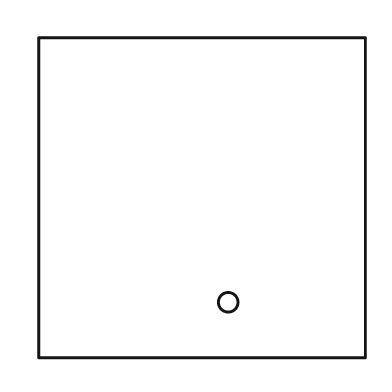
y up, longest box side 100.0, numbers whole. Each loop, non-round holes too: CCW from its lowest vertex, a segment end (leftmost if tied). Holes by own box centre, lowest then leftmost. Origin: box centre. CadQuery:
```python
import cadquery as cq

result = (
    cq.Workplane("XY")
    .moveTo(-50.0, -49.0)
    .lineTo(50.0, -49.0)
    .lineTo(50.0, 49.0)
    .lineTo(-50.0, 49.0)
    .close()
    .moveTo(8.0, -32.0)
    .circle(3.0)
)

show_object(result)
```